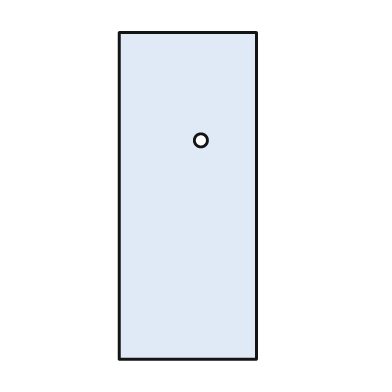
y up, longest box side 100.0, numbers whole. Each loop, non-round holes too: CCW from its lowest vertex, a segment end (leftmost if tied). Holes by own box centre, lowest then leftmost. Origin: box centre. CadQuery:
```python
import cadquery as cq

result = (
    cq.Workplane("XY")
    .moveTo(-21.0, -50.0)
    .lineTo(21.0, -50.0)
    .lineTo(21.0, 50.0)
    .lineTo(-21.0, 50.0)
    .close()
    .moveTo(4.0, 17.0)
    .circle(2.0)
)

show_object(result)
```